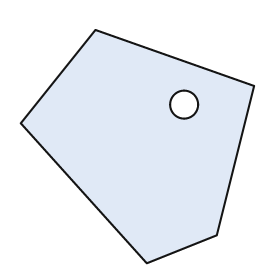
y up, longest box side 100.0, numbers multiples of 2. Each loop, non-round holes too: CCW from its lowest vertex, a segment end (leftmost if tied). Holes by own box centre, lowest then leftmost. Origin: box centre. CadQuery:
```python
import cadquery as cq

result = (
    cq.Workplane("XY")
    .moveTo(4.0, -50.0)
    .lineTo(34.0, -38.0)
    .lineTo(50.0, 26.0)
    .lineTo(-18.0, 50.0)
    .lineTo(-50.0, 10.0)
    .close()
    .moveTo(20.0, 18.0)
    .circle(6.0)
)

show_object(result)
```